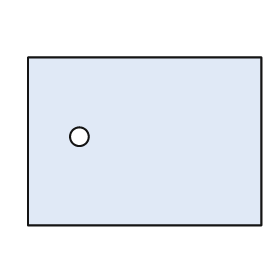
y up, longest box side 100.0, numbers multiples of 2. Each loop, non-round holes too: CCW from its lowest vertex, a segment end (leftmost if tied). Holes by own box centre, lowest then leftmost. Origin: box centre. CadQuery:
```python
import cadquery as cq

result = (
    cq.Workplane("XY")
    .moveTo(-50.0, -36.0)
    .lineTo(50.0, -36.0)
    .lineTo(50.0, 36.0)
    .lineTo(-50.0, 36.0)
    .close()
    .moveTo(-28.0, 2.0)
    .circle(4.0)
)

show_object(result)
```